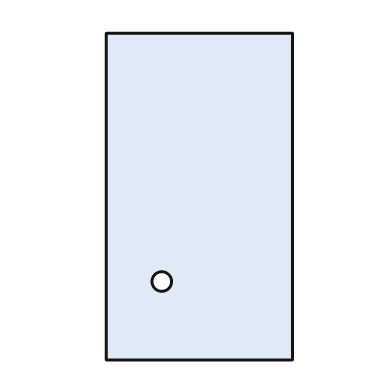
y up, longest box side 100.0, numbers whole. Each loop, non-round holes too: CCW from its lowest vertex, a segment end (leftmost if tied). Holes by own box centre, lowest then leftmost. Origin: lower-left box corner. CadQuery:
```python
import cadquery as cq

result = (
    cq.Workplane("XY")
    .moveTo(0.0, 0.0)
    .lineTo(57.0, 0.0)
    .lineTo(57.0, 100.0)
    .lineTo(0.0, 100.0)
    .close()
    .moveTo(17.0, 24.0)
    .circle(3.0)
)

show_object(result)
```